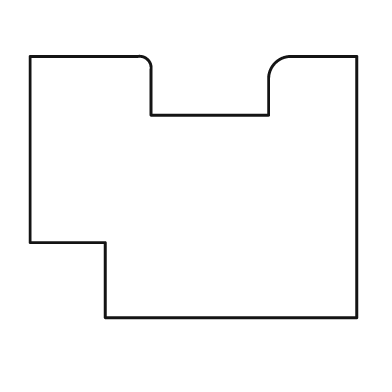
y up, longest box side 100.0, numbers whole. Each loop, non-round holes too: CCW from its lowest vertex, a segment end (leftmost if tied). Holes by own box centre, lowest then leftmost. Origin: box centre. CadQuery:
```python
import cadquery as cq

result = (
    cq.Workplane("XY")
    .moveTo(-27.0, -40.0)
    .lineTo(50.0, -40.0)
    .lineTo(50.0, 40.0)
    .lineTo(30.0, 40.0)
    .threePointArc((25.0, 38.0), (23.0, 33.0))
    .lineTo(23.0, 22.0)
    .lineTo(-13.0, 22.0)
    .lineTo(-13.0, 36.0)
    .threePointArc((-14.0, 39.0), (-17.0, 40.0))
    .lineTo(-50.0, 40.0)
    .lineTo(-50.0, -17.0)
    .lineTo(-27.0, -17.0)
    .close()
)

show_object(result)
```